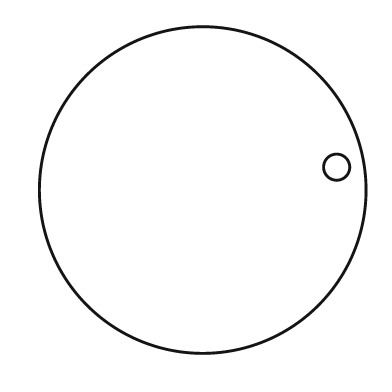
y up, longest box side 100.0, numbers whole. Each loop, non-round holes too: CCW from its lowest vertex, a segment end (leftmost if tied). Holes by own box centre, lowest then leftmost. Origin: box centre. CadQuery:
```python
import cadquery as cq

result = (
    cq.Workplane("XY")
    .moveTo(0.0, 0.0)
    .circle(50.0)
    .moveTo(41.0, 7.0)
    .circle(4.0)
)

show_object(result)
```